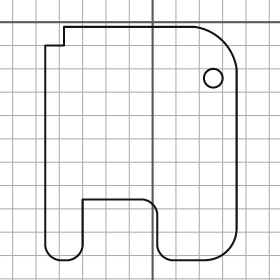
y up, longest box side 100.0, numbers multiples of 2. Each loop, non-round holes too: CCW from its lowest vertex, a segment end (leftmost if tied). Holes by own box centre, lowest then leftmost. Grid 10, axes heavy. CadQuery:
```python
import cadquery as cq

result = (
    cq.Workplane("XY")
    .moveTo(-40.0, -102.0)
    .lineTo(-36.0, -102.0)
    .threePointArc((-32.0, -100.0), (-30.0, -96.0))
    .lineTo(-30.0, -76.0)
    .lineTo(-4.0, -76.0)
    .threePointArc((0.0, -78.0), (2.0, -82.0))
    .lineTo(2.0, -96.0)
    .threePointArc((4.0, -100.0), (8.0, -102.0))
    .lineTo(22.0, -102.0)
    .threePointArc((32.0, -98.0), (36.0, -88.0))
    .lineTo(36.0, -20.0)
    .threePointArc((30.0, -8.0), (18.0, -2.0))
    .lineTo(-38.0, -2.0)
    .lineTo(-38.0, -10.0)
    .lineTo(-46.0, -10.0)
    .lineTo(-46.0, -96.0)
    .threePointArc((-44.0, -100.0), (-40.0, -102.0))
    .close()
    .moveTo(26.0, -24.0)
    .circle(4.0)
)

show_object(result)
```